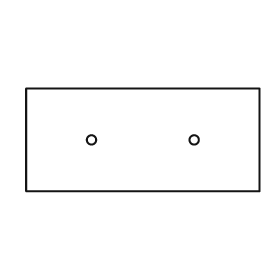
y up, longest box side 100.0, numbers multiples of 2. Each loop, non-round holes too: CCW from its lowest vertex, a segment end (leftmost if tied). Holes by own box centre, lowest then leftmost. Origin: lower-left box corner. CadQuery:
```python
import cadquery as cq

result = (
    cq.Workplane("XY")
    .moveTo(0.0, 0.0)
    .lineTo(100.0, 0.0)
    .lineTo(100.0, 44.0)
    .lineTo(0.0, 44.0)
    .close()
    .moveTo(28.0, 22.0)
    .circle(2.0)
    .moveTo(72.0, 22.0)
    .circle(2.0)
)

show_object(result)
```